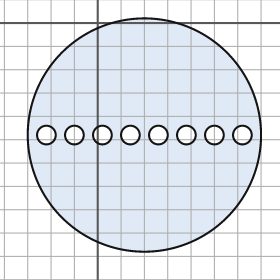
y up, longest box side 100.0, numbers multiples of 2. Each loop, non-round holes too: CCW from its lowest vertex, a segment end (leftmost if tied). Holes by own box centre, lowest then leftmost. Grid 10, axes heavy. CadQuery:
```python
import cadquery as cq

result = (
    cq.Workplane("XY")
    .moveTo(20.0, -48.0)
    .circle(50.0)
    .moveTo(-22.0, -48.0)
    .circle(4.0)
    .moveTo(-10.0, -48.0)
    .circle(4.0)
    .moveTo(2.0, -48.0)
    .circle(4.0)
    .moveTo(14.0, -48.0)
    .circle(4.0)
    .moveTo(26.0, -48.0)
    .circle(4.0)
    .moveTo(38.0, -48.0)
    .circle(4.0)
    .moveTo(50.0, -48.0)
    .circle(4.0)
    .moveTo(62.0, -48.0)
    .circle(4.0)
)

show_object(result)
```